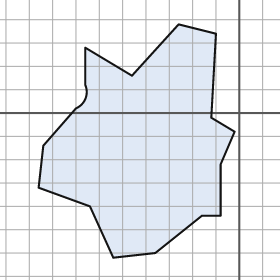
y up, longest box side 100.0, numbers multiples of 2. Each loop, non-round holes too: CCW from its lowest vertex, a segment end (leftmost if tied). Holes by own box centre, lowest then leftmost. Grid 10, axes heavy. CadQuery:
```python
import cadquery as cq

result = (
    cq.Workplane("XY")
    .moveTo(-54.0, -62.0)
    .lineTo(-36.0, -60.0)
    .lineTo(-16.0, -44.0)
    .lineTo(-8.0, -44.0)
    .lineTo(-8.0, -22.0)
    .lineTo(-2.0, -8.0)
    .lineTo(-12.0, -2.0)
    .lineTo(-10.0, 34.0)
    .lineTo(-26.0, 38.0)
    .lineTo(-46.0, 16.0)
    .lineTo(-66.0, 28.0)
    .lineTo(-66.0, 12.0)
    .threePointArc((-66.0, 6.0), (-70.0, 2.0))
    .lineTo(-84.0, -14.0)
    .lineTo(-86.0, -32.0)
    .lineTo(-64.0, -40.0)
    .close()
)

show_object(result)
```